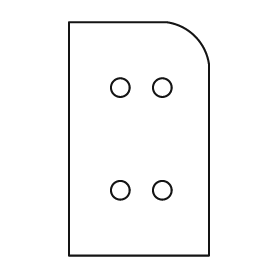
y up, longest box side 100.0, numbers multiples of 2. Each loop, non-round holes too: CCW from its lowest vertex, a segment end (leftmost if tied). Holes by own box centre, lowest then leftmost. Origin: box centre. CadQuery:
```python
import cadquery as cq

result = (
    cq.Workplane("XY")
    .moveTo(-30.0, -50.0)
    .lineTo(30.0, -50.0)
    .lineTo(30.0, 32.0)
    .threePointArc((24.0, 44.0), (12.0, 50.0))
    .lineTo(-30.0, 50.0)
    .close()
    .moveTo(-8.0, -22.0)
    .circle(4.0)
    .moveTo(10.0, -22.0)
    .circle(4.0)
    .moveTo(-8.0, 22.0)
    .circle(4.0)
    .moveTo(10.0, 22.0)
    .circle(4.0)
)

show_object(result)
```